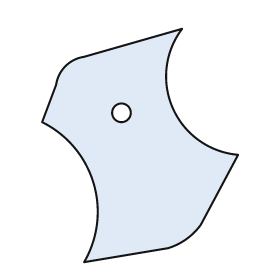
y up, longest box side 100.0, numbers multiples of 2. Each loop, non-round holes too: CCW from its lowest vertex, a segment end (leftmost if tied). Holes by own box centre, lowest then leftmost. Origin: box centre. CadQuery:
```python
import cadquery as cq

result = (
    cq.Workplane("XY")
    .moveTo(-24.0, -50.0)
    .lineTo(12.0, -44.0)
    .threePointArc((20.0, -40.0), (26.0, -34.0))
    .lineTo(42.0, -4.0)
    .threePointArc((14.0, 16.0), (18.0, 50.0))
    .lineTo(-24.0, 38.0)
    .threePointArc((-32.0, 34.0), (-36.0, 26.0))
    .lineTo(-42.0, 10.0)
    .threePointArc((-20.0, -16.0), (-24.0, -50.0))
    .close()
    .moveTo(-8.0, 14.0)
    .circle(4.0)
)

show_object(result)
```